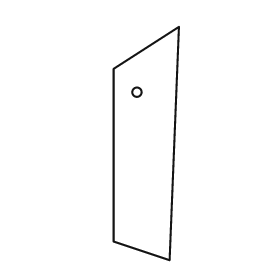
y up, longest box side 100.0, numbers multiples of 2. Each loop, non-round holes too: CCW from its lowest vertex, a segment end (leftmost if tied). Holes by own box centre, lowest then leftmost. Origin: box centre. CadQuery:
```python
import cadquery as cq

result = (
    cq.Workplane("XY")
    .moveTo(10.0, -50.0)
    .lineTo(14.0, 50.0)
    .lineTo(-14.0, 32.0)
    .lineTo(-14.0, -42.0)
    .close()
    .moveTo(-4.0, 22.0)
    .circle(2.0)
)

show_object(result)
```